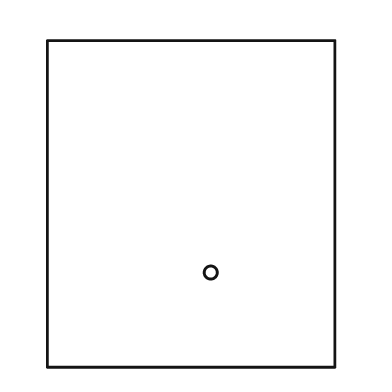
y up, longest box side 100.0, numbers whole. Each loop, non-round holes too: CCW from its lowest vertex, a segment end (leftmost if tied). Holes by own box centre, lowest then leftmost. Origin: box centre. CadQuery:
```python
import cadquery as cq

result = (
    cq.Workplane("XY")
    .moveTo(-44.0, -50.0)
    .lineTo(44.0, -50.0)
    .lineTo(44.0, 50.0)
    .lineTo(-44.0, 50.0)
    .close()
    .moveTo(6.0, -21.0)
    .circle(2.0)
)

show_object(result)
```